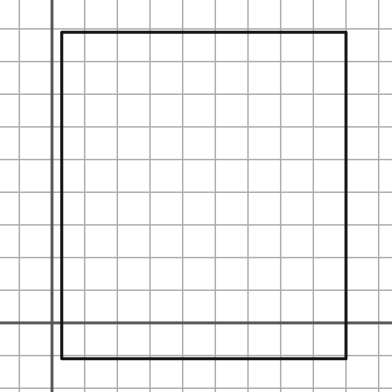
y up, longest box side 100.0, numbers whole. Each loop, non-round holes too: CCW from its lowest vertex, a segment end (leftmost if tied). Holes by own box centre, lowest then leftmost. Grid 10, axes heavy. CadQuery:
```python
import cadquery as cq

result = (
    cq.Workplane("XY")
    .moveTo(3.0, -11.0)
    .lineTo(90.0, -11.0)
    .lineTo(90.0, 89.0)
    .lineTo(3.0, 89.0)
    .close()
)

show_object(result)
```